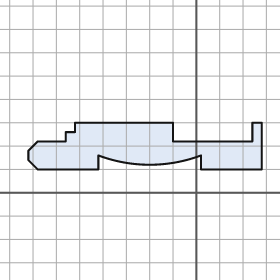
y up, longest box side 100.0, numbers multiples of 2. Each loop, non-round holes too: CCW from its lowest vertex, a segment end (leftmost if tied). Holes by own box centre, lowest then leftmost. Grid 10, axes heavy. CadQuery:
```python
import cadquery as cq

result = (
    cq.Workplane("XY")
    .moveTo(-68.0, 10.0)
    .lineTo(-42.0, 10.0)
    .lineTo(-42.0, 16.0)
    .threePointArc((-20.0, 12.0), (2.0, 16.0))
    .lineTo(2.0, 10.0)
    .lineTo(28.0, 10.0)
    .lineTo(28.0, 30.0)
    .lineTo(24.0, 30.0)
    .lineTo(24.0, 22.0)
    .lineTo(-10.0, 22.0)
    .lineTo(-10.0, 30.0)
    .lineTo(-52.0, 30.0)
    .lineTo(-52.0, 26.0)
    .lineTo(-56.0, 26.0)
    .lineTo(-56.0, 22.0)
    .lineTo(-68.0, 22.0)
    .lineTo(-72.0, 18.0)
    .lineTo(-72.0, 14.0)
    .close()
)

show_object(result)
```